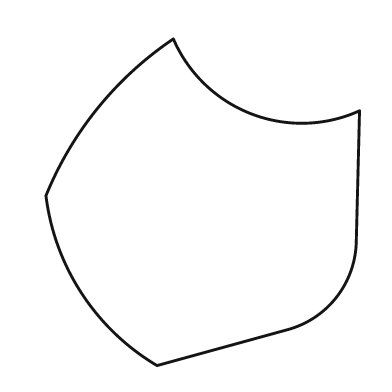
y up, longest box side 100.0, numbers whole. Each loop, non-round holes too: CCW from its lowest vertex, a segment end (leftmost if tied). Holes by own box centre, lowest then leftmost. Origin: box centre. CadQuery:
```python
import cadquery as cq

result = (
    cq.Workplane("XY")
    .moveTo(-14.0, -50.0)
    .lineTo(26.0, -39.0)
    .threePointArc((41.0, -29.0), (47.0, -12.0))
    .lineTo(48.0, 28.0)
    .threePointArc((15.0, 27.0), (-9.0, 50.0))
    .threePointArc((-32.0, 29.0), (-48.0, 2.0))
    .threePointArc((-37.0, -28.0), (-14.0, -50.0))
    .close()
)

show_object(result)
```